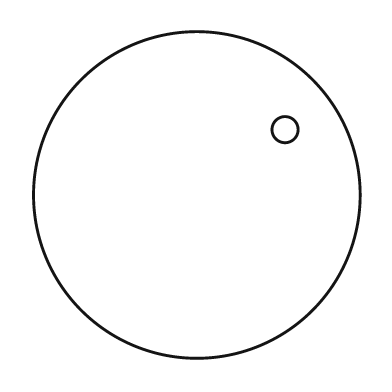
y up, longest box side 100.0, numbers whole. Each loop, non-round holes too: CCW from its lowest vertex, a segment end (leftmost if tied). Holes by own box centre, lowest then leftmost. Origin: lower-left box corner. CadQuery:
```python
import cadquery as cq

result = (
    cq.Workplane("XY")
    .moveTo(50.0, 50.0)
    .circle(50.0)
    .moveTo(77.0, 70.0)
    .circle(4.0)
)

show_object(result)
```